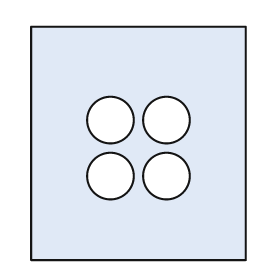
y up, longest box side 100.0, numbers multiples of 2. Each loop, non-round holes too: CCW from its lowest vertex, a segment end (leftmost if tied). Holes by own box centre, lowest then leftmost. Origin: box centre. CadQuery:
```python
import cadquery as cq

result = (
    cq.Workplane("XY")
    .moveTo(-46.0, -50.0)
    .lineTo(46.0, -50.0)
    .lineTo(46.0, 50.0)
    .lineTo(-46.0, 50.0)
    .close()
    .moveTo(-12.0, -14.0)
    .circle(10.0)
    .moveTo(12.0, -14.0)
    .circle(10.0)
    .moveTo(-12.0, 10.0)
    .circle(10.0)
    .moveTo(12.0, 10.0)
    .circle(10.0)
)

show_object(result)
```